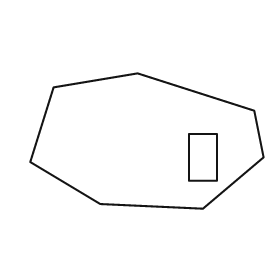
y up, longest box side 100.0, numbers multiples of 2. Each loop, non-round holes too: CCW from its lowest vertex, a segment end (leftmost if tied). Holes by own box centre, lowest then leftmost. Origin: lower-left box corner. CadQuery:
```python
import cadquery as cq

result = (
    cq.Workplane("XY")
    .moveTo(74.0, 0.0)
    .lineTo(100.0, 22.0)
    .lineTo(96.0, 42.0)
    .lineTo(46.0, 58.0)
    .lineTo(10.0, 52.0)
    .lineTo(0.0, 20.0)
    .lineTo(30.0, 2.0)
    .close()
    .moveTo(68.0, 12.0)
    .lineTo(80.0, 12.0)
    .lineTo(80.0, 32.0)
    .lineTo(68.0, 32.0)
    .close()
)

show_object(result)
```